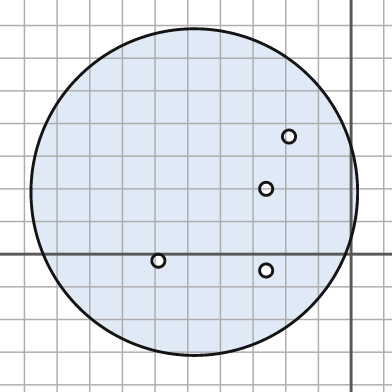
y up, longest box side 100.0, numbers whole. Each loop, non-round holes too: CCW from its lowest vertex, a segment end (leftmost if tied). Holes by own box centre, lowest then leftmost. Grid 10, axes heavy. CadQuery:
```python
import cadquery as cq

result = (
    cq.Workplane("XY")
    .moveTo(-48.0, 19.0)
    .circle(50.0)
    .moveTo(-26.0, -5.0)
    .circle(2.0)
    .moveTo(-59.0, -2.0)
    .circle(2.0)
    .moveTo(-26.0, 20.0)
    .circle(2.0)
    .moveTo(-19.0, 36.0)
    .circle(2.0)
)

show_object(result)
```